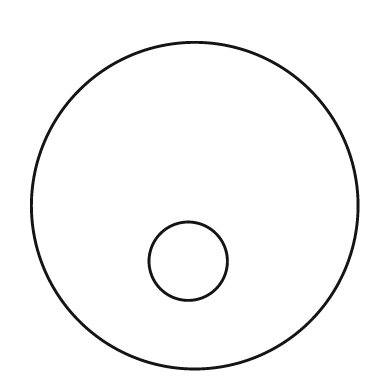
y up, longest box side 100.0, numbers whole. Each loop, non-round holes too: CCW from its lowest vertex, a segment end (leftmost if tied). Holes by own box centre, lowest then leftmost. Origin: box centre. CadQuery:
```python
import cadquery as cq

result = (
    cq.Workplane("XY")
    .moveTo(0.0, 0.0)
    .circle(50.0)
    .moveTo(-2.0, -17.0)
    .circle(12.0)
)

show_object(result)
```